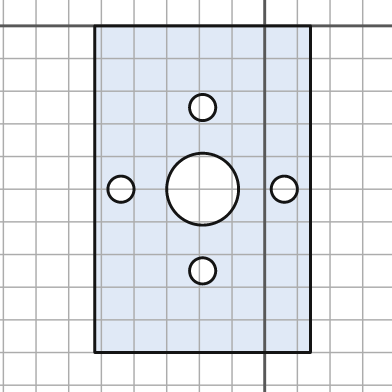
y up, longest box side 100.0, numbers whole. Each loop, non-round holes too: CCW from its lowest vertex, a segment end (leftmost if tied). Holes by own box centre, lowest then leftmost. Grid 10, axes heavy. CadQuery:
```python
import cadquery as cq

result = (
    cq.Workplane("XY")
    .moveTo(-52.0, -100.0)
    .lineTo(14.0, -100.0)
    .lineTo(14.0, 0.0)
    .lineTo(-52.0, 0.0)
    .close()
    .moveTo(-19.0, -75.0)
    .circle(4.0)
    .moveTo(-44.0, -50.0)
    .circle(4.0)
    .moveTo(-19.0, -50.0)
    .circle(11.0)
    .moveTo(6.0, -50.0)
    .circle(4.0)
    .moveTo(-19.0, -25.0)
    .circle(4.0)
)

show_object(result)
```